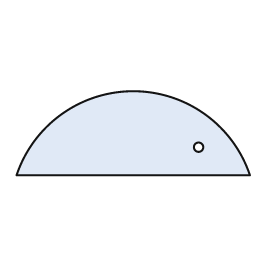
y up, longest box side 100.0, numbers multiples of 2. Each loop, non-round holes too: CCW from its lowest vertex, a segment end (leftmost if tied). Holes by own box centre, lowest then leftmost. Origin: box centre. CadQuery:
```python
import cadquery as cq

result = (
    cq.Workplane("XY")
    .moveTo(-50.0, -18.0)
    .lineTo(50.0, -18.0)
    .threePointArc((0.0, 18.0), (-50.0, -18.0))
    .close()
    .moveTo(28.0, -6.0)
    .circle(2.0)
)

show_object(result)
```